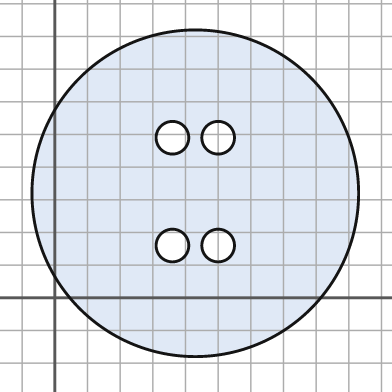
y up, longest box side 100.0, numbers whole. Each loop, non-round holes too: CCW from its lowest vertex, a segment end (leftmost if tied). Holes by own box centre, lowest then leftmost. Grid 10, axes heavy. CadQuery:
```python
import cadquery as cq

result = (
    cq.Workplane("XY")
    .moveTo(43.0, 32.0)
    .circle(50.0)
    .moveTo(36.0, 16.0)
    .circle(5.0)
    .moveTo(50.0, 16.0)
    .circle(5.0)
    .moveTo(36.0, 49.0)
    .circle(5.0)
    .moveTo(50.0, 49.0)
    .circle(5.0)
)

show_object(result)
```